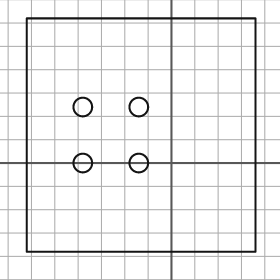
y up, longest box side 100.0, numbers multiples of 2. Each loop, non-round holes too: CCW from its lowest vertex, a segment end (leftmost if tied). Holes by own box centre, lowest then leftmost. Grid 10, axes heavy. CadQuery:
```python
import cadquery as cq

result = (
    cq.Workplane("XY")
    .moveTo(-62.0, -38.0)
    .lineTo(36.0, -38.0)
    .lineTo(36.0, 62.0)
    .lineTo(-62.0, 62.0)
    .close()
    .moveTo(-38.0, 0.0)
    .circle(4.0)
    .moveTo(-14.0, 0.0)
    .circle(4.0)
    .moveTo(-38.0, 24.0)
    .circle(4.0)
    .moveTo(-14.0, 24.0)
    .circle(4.0)
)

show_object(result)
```